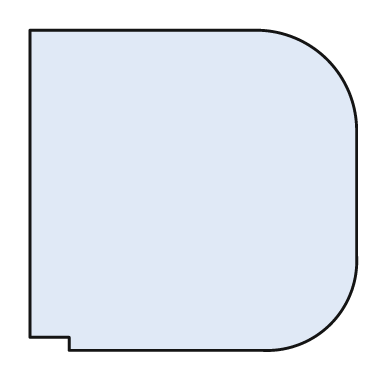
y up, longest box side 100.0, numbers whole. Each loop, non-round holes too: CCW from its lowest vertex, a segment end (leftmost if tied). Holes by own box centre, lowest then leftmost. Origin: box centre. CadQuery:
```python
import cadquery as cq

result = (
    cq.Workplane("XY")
    .moveTo(-38.0, -49.0)
    .lineTo(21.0, -49.0)
    .threePointArc((42.0, -41.0), (50.0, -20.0))
    .lineTo(50.0, 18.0)
    .threePointArc((41.0, 40.0), (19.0, 49.0))
    .lineTo(-50.0, 49.0)
    .lineTo(-50.0, -45.0)
    .lineTo(-38.0, -45.0)
    .close()
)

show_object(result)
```